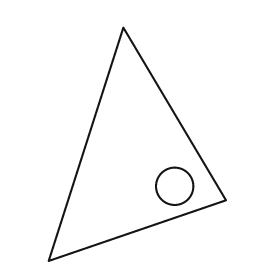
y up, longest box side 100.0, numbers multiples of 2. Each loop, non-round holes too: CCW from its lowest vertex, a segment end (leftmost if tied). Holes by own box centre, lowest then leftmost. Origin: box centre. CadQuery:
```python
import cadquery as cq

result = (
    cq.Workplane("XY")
    .moveTo(-38.0, -50.0)
    .lineTo(38.0, -24.0)
    .lineTo(-6.0, 50.0)
    .close()
    .moveTo(16.0, -18.0)
    .circle(8.0)
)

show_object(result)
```